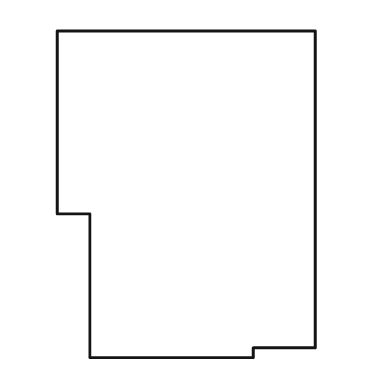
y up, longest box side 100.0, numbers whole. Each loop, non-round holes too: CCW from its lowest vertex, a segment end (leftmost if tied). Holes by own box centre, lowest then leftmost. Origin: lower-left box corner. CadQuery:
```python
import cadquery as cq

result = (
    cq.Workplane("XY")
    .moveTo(10.0, 0.0)
    .lineTo(60.0, 0.0)
    .lineTo(60.0, 3.0)
    .lineTo(79.0, 3.0)
    .lineTo(79.0, 100.0)
    .lineTo(0.0, 100.0)
    .lineTo(0.0, 44.0)
    .lineTo(10.0, 44.0)
    .close()
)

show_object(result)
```